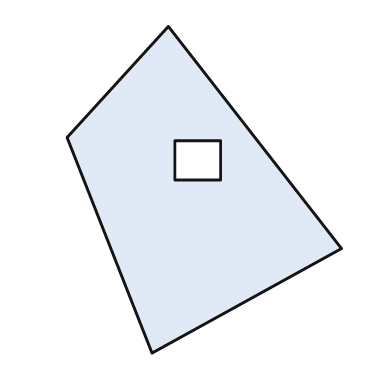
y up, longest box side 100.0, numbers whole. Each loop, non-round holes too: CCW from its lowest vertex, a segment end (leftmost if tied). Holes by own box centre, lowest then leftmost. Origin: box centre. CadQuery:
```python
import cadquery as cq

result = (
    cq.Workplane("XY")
    .moveTo(-16.0, -50.0)
    .lineTo(42.0, -18.0)
    .lineTo(-11.0, 50.0)
    .lineTo(-42.0, 16.0)
    .close()
    .moveTo(-9.0, 3.0)
    .lineTo(5.0, 3.0)
    .lineTo(5.0, 15.0)
    .lineTo(-9.0, 15.0)
    .close()
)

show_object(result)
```